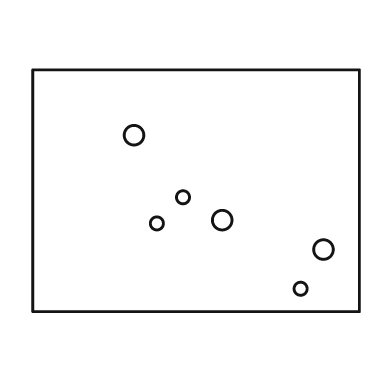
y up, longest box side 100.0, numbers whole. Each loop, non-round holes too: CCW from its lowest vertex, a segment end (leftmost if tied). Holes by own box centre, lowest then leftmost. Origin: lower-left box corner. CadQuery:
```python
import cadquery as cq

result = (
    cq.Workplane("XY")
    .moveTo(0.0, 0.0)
    .lineTo(100.0, 0.0)
    .lineTo(100.0, 74.0)
    .lineTo(0.0, 74.0)
    .close()
    .moveTo(82.0, 7.0)
    .circle(2.0)
    .moveTo(89.0, 19.0)
    .circle(3.0)
    .moveTo(38.0, 27.0)
    .circle(2.0)
    .moveTo(58.0, 28.0)
    .circle(3.0)
    .moveTo(46.0, 35.0)
    .circle(2.0)
    .moveTo(31.0, 54.0)
    .circle(3.0)
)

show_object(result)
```